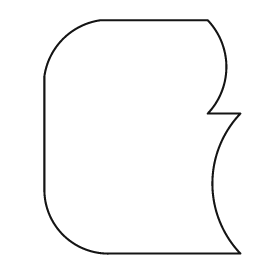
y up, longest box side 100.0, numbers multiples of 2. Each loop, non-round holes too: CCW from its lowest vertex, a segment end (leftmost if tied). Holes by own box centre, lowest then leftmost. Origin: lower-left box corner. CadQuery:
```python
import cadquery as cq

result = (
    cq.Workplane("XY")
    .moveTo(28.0, 0.0)
    .lineTo(84.0, 0.0)
    .threePointArc((72.0, 30.0), (84.0, 60.0))
    .lineTo(70.0, 60.0)
    .threePointArc((78.0, 80.0), (70.0, 100.0))
    .lineTo(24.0, 100.0)
    .threePointArc((8.0, 92.0), (0.0, 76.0))
    .lineTo(0.0, 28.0)
    .threePointArc((8.0, 8.0), (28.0, 0.0))
    .close()
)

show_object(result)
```